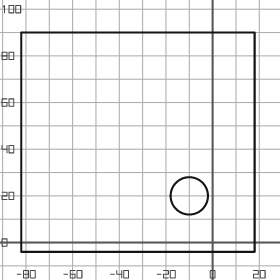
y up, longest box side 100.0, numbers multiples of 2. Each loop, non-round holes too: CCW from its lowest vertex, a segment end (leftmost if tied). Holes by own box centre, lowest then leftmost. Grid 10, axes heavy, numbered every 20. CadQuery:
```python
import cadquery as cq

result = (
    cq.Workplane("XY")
    .moveTo(-82.0, -4.0)
    .lineTo(18.0, -4.0)
    .lineTo(18.0, 90.0)
    .lineTo(-82.0, 90.0)
    .close()
    .moveTo(-10.0, 20.0)
    .circle(8.0)
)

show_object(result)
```